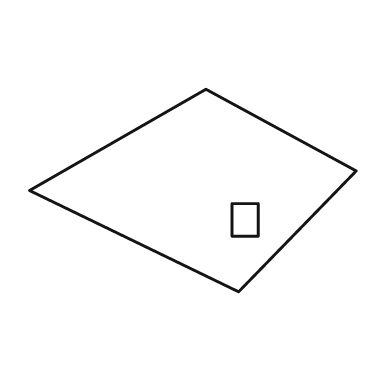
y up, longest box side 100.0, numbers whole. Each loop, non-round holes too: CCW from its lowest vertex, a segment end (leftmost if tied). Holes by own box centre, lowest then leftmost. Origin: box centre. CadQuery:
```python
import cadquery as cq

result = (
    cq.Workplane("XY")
    .moveTo(14.0, -31.0)
    .lineTo(50.0, 6.0)
    .lineTo(4.0, 31.0)
    .lineTo(-50.0, 0.0)
    .close()
    .moveTo(12.0, -14.0)
    .lineTo(20.0, -14.0)
    .lineTo(20.0, -4.0)
    .lineTo(12.0, -4.0)
    .close()
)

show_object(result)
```